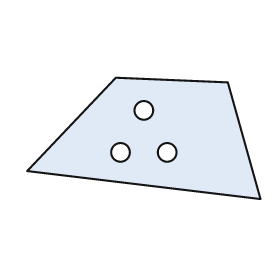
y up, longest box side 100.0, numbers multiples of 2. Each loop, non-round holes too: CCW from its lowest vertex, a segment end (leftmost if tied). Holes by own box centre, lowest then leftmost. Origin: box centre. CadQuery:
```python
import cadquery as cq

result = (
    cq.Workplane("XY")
    .moveTo(50.0, -26.0)
    .lineTo(36.0, 24.0)
    .lineTo(-12.0, 26.0)
    .lineTo(-50.0, -14.0)
    .close()
    .moveTo(-10.0, -6.0)
    .circle(4.0)
    .moveTo(10.0, -6.0)
    .circle(4.0)
    .moveTo(0.0, 12.0)
    .circle(4.0)
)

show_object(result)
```